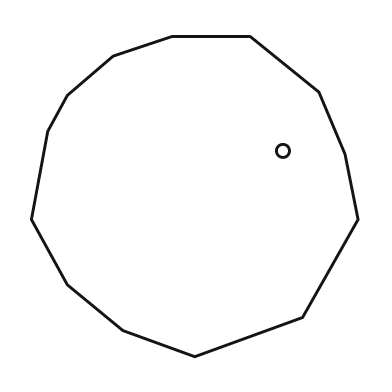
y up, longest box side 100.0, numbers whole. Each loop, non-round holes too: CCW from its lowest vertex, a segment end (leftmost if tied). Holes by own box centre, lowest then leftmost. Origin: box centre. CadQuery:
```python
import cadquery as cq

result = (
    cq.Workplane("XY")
    .moveTo(0.0, -49.0)
    .lineTo(33.0, -37.0)
    .lineTo(50.0, -7.0)
    .lineTo(46.0, 13.0)
    .lineTo(38.0, 32.0)
    .lineTo(17.0, 49.0)
    .lineTo(-7.0, 49.0)
    .lineTo(-25.0, 43.0)
    .lineTo(-39.0, 31.0)
    .lineTo(-45.0, 20.0)
    .lineTo(-50.0, -7.0)
    .lineTo(-39.0, -27.0)
    .lineTo(-22.0, -41.0)
    .close()
    .moveTo(27.0, 14.0)
    .circle(2.0)
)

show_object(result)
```